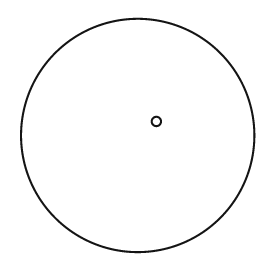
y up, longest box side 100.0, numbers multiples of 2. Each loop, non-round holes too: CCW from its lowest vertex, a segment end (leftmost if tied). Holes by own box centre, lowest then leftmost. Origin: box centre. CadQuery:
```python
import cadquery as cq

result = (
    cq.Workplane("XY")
    .moveTo(0.0, 0.0)
    .circle(50.0)
    .moveTo(8.0, 6.0)
    .circle(2.0)
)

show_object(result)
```